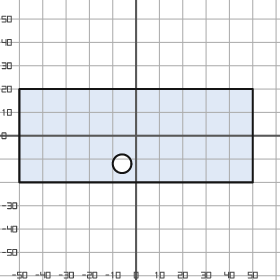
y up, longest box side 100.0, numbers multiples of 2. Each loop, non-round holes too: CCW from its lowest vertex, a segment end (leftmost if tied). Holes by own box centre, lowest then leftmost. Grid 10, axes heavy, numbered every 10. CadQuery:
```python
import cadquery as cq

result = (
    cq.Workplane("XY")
    .moveTo(-50.0, -20.0)
    .lineTo(50.0, -20.0)
    .lineTo(50.0, 20.0)
    .lineTo(-50.0, 20.0)
    .close()
    .moveTo(-6.0, -12.0)
    .circle(4.0)
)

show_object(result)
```